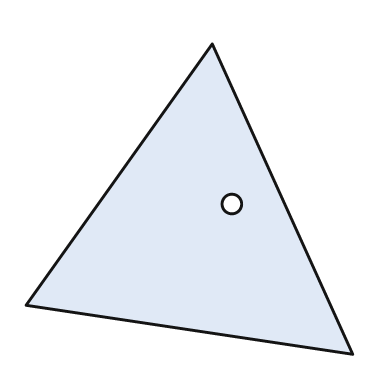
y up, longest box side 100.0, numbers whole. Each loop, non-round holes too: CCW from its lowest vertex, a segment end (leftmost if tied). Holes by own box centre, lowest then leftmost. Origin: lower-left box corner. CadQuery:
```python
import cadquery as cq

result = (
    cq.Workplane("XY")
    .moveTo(100.0, 0.0)
    .lineTo(57.0, 95.0)
    .lineTo(0.0, 15.0)
    .close()
    .moveTo(63.0, 46.0)
    .circle(3.0)
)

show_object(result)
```